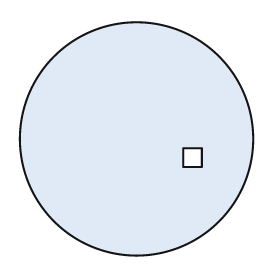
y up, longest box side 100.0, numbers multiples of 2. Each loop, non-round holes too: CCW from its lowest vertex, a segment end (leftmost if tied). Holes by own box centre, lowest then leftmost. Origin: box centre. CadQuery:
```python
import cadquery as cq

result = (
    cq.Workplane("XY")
    .moveTo(0.0, 0.0)
    .circle(50.0)
    .moveTo(20.0, -12.0)
    .lineTo(28.0, -12.0)
    .lineTo(28.0, -4.0)
    .lineTo(20.0, -4.0)
    .close()
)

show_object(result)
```